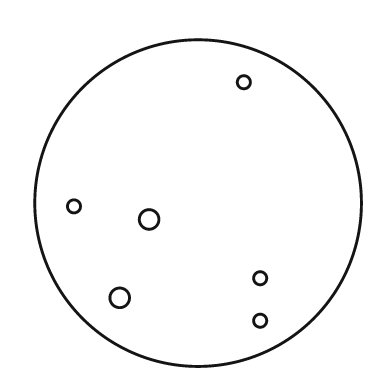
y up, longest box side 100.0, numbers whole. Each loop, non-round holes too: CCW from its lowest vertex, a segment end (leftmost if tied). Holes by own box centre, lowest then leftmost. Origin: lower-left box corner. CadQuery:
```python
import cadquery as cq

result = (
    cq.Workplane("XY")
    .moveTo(50.0, 50.0)
    .circle(50.0)
    .moveTo(69.0, 14.0)
    .circle(2.0)
    .moveTo(26.0, 21.0)
    .circle(3.0)
    .moveTo(69.0, 27.0)
    .circle(2.0)
    .moveTo(35.0, 45.0)
    .circle(3.0)
    .moveTo(12.0, 49.0)
    .circle(2.0)
    .moveTo(64.0, 87.0)
    .circle(2.0)
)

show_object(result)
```